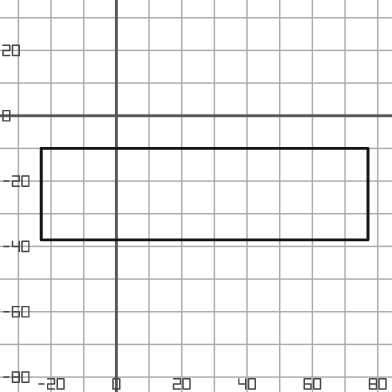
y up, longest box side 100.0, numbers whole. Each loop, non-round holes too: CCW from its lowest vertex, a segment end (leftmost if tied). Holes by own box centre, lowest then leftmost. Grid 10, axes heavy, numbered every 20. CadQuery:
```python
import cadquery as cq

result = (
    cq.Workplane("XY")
    .moveTo(-23.0, -38.0)
    .lineTo(77.0, -38.0)
    .lineTo(77.0, -10.0)
    .lineTo(-23.0, -10.0)
    .close()
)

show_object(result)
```